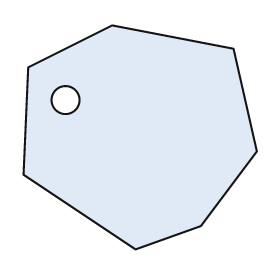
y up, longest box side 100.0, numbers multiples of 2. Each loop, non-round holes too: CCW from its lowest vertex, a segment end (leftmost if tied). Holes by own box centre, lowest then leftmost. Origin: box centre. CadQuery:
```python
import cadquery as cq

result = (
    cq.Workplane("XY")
    .moveTo(-2.0, -48.0)
    .lineTo(26.0, -38.0)
    .lineTo(50.0, -6.0)
    .lineTo(40.0, 38.0)
    .lineTo(-12.0, 48.0)
    .lineTo(-48.0, 30.0)
    .lineTo(-50.0, -16.0)
    .close()
    .moveTo(-32.0, 16.0)
    .circle(6.0)
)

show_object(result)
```